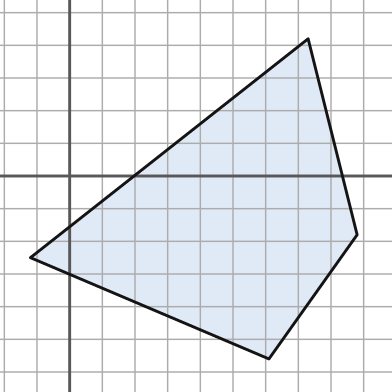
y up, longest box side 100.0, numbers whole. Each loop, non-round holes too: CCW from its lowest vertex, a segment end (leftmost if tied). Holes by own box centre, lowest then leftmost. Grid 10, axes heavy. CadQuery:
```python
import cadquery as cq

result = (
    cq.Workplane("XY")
    .moveTo(61.0, -56.0)
    .lineTo(88.0, -18.0)
    .lineTo(73.0, 42.0)
    .lineTo(-12.0, -25.0)
    .close()
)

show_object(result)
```